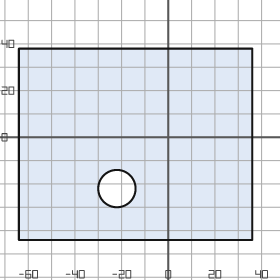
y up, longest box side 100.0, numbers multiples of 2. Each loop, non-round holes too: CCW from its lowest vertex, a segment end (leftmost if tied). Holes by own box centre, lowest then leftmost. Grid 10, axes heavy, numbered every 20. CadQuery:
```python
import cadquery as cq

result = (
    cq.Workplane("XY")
    .moveTo(-64.0, -44.0)
    .lineTo(36.0, -44.0)
    .lineTo(36.0, 38.0)
    .lineTo(-64.0, 38.0)
    .close()
    .moveTo(-22.0, -22.0)
    .circle(8.0)
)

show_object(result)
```